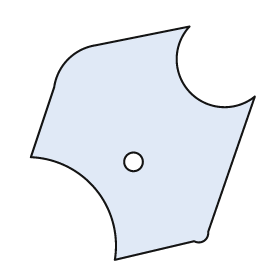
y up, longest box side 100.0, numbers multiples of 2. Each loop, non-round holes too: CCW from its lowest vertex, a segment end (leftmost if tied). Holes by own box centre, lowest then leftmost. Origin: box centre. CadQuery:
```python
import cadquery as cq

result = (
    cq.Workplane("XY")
    .moveTo(-12.0, -50.0)
    .lineTo(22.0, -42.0)
    .threePointArc((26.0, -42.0), (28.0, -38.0))
    .lineTo(48.0, 20.0)
    .threePointArc((20.0, 22.0), (20.0, 50.0))
    .lineTo(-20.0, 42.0)
    .threePointArc((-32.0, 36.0), (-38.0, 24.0))
    .lineTo(-48.0, -6.0)
    .threePointArc((-20.0, -20.0), (-12.0, -50.0))
    .close()
    .moveTo(-4.0, -8.0)
    .circle(4.0)
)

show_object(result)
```